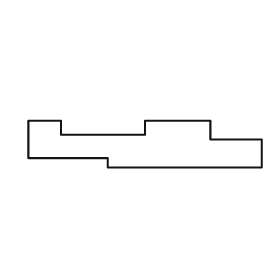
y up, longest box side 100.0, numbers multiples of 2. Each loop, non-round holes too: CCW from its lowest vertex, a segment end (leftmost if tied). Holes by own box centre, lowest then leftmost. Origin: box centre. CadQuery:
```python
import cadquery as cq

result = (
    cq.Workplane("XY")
    .moveTo(-16.0, -10.0)
    .lineTo(50.0, -10.0)
    .lineTo(50.0, 2.0)
    .lineTo(28.0, 2.0)
    .lineTo(28.0, 10.0)
    .lineTo(0.0, 10.0)
    .lineTo(0.0, 4.0)
    .lineTo(-36.0, 4.0)
    .lineTo(-36.0, 10.0)
    .lineTo(-50.0, 10.0)
    .lineTo(-50.0, -6.0)
    .lineTo(-16.0, -6.0)
    .close()
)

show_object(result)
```